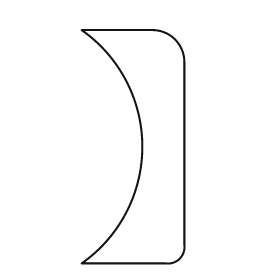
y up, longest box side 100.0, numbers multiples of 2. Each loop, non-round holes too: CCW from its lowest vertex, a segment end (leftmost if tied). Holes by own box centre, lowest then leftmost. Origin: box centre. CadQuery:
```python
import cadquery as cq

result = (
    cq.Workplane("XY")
    .moveTo(-22.0, -50.0)
    .lineTo(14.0, -50.0)
    .threePointArc((20.0, -48.0), (22.0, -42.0))
    .lineTo(22.0, 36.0)
    .threePointArc((18.0, 46.0), (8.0, 50.0))
    .lineTo(-22.0, 50.0)
    .threePointArc((4.0, 0.0), (-22.0, -50.0))
    .close()
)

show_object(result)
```